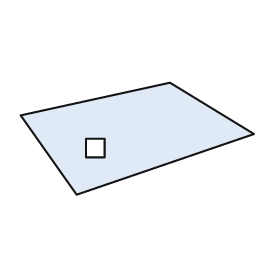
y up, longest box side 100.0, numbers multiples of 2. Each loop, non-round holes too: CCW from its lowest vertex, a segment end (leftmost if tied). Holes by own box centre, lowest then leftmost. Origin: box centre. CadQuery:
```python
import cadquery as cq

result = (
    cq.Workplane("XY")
    .moveTo(-26.0, -24.0)
    .lineTo(50.0, 2.0)
    .lineTo(14.0, 24.0)
    .lineTo(-50.0, 10.0)
    .close()
    .moveTo(-22.0, -8.0)
    .lineTo(-14.0, -8.0)
    .lineTo(-14.0, 0.0)
    .lineTo(-22.0, 0.0)
    .close()
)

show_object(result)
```